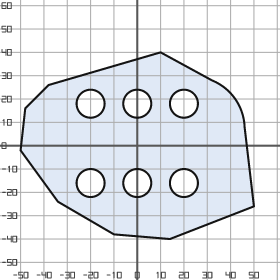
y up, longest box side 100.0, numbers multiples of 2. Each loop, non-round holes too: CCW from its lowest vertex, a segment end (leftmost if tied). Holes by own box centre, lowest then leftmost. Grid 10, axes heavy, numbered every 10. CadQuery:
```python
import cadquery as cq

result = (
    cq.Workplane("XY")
    .moveTo(14.0, -40.0)
    .lineTo(50.0, -26.0)
    .lineTo(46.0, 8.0)
    .threePointArc((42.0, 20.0), (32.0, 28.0))
    .lineTo(10.0, 40.0)
    .lineTo(-38.0, 26.0)
    .lineTo(-48.0, 16.0)
    .lineTo(-50.0, -2.0)
    .lineTo(-34.0, -24.0)
    .lineTo(-10.0, -38.0)
    .close()
    .moveTo(-20.0, -16.0)
    .circle(6.0)
    .moveTo(0.0, -16.0)
    .circle(6.0)
    .moveTo(20.0, -16.0)
    .circle(6.0)
    .moveTo(-20.0, 18.0)
    .circle(6.0)
    .moveTo(0.0, 18.0)
    .circle(6.0)
    .moveTo(20.0, 18.0)
    .circle(6.0)
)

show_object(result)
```